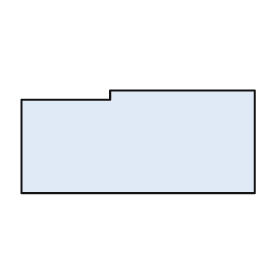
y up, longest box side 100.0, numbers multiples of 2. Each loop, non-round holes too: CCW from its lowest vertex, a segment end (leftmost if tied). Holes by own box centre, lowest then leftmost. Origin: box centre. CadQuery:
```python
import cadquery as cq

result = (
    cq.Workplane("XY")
    .moveTo(-50.0, -22.0)
    .lineTo(50.0, -22.0)
    .lineTo(50.0, 22.0)
    .lineTo(-12.0, 22.0)
    .lineTo(-12.0, 18.0)
    .lineTo(-50.0, 18.0)
    .close()
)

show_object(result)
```